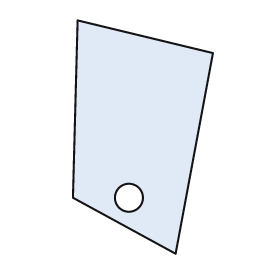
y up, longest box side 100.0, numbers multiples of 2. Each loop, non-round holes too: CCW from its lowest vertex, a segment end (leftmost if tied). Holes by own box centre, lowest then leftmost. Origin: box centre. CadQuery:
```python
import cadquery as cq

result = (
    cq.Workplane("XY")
    .moveTo(14.0, -50.0)
    .lineTo(30.0, 36.0)
    .lineTo(-28.0, 50.0)
    .lineTo(-30.0, -26.0)
    .close()
    .moveTo(-6.0, -26.0)
    .circle(6.0)
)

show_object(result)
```